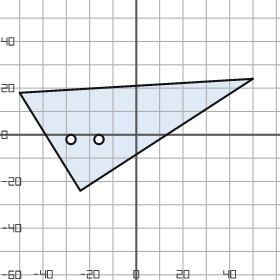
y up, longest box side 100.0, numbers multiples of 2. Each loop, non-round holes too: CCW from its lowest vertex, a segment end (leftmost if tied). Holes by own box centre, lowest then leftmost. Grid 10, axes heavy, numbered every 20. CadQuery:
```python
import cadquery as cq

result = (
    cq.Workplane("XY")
    .moveTo(-24.0, -24.0)
    .lineTo(50.0, 24.0)
    .lineTo(-50.0, 18.0)
    .close()
    .moveTo(-28.0, -2.0)
    .circle(2.0)
    .moveTo(-16.0, -2.0)
    .circle(2.0)
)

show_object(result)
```